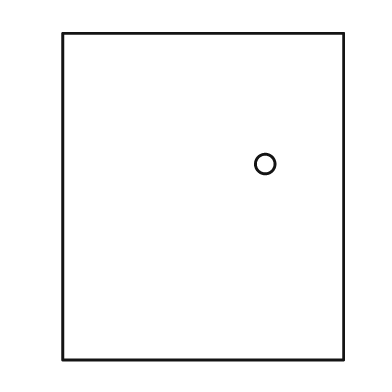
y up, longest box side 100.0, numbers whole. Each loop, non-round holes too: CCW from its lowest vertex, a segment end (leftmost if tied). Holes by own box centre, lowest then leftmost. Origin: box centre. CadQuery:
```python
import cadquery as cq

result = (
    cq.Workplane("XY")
    .moveTo(-43.0, -50.0)
    .lineTo(43.0, -50.0)
    .lineTo(43.0, 50.0)
    .lineTo(-43.0, 50.0)
    .close()
    .moveTo(19.0, 10.0)
    .circle(3.0)
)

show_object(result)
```